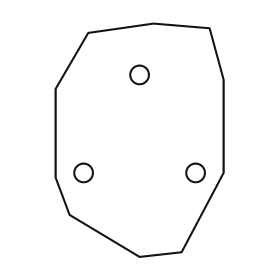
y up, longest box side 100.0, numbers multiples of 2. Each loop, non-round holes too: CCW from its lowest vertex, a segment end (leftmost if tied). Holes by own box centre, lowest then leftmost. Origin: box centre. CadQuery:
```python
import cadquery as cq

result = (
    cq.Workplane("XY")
    .moveTo(0.0, -50.0)
    .lineTo(18.0, -48.0)
    .lineTo(36.0, -14.0)
    .lineTo(36.0, 26.0)
    .lineTo(30.0, 48.0)
    .lineTo(6.0, 50.0)
    .lineTo(-22.0, 46.0)
    .lineTo(-36.0, 22.0)
    .lineTo(-36.0, -16.0)
    .lineTo(-30.0, -32.0)
    .close()
    .moveTo(-24.0, -14.0)
    .circle(4.0)
    .moveTo(24.0, -14.0)
    .circle(4.0)
    .moveTo(0.0, 28.0)
    .circle(4.0)
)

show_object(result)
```